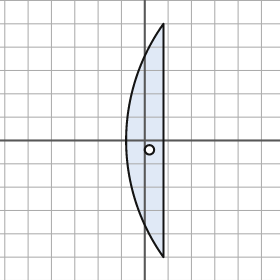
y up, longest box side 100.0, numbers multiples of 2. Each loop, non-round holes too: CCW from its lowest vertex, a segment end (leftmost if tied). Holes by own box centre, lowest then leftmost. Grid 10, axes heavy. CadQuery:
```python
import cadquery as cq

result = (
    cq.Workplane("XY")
    .moveTo(8.0, -50.0)
    .lineTo(8.0, 50.0)
    .threePointArc((-8.0, 0.0), (8.0, -50.0))
    .close()
    .moveTo(2.0, -4.0)
    .circle(2.0)
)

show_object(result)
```